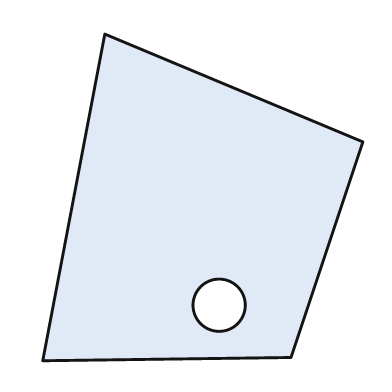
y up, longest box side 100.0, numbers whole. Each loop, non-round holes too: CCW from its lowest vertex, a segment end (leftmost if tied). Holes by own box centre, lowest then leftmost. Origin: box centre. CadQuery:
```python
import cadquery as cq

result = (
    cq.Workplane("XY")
    .moveTo(-49.0, -50.0)
    .lineTo(27.0, -49.0)
    .lineTo(49.0, 17.0)
    .lineTo(-30.0, 50.0)
    .close()
    .moveTo(5.0, -33.0)
    .circle(8.0)
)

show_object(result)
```